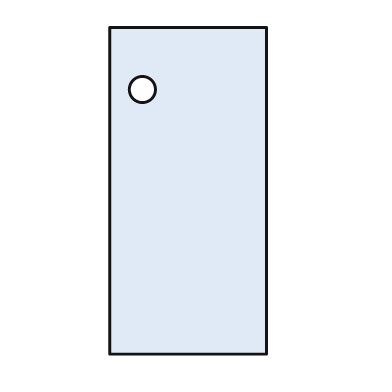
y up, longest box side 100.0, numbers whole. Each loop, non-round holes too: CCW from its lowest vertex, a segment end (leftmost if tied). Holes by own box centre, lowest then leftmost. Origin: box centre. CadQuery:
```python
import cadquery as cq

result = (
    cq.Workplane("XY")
    .moveTo(-24.0, -50.0)
    .lineTo(24.0, -50.0)
    .lineTo(24.0, 50.0)
    .lineTo(-24.0, 50.0)
    .close()
    .moveTo(-14.0, 31.0)
    .circle(4.0)
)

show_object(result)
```